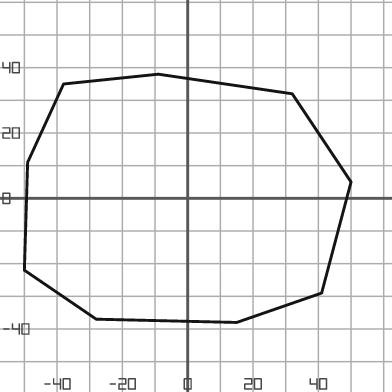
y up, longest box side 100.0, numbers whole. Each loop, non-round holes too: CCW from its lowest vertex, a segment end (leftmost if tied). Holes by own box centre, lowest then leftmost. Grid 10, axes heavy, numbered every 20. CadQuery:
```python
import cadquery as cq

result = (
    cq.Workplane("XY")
    .moveTo(15.0, -38.0)
    .lineTo(41.0, -29.0)
    .lineTo(50.0, 5.0)
    .lineTo(32.0, 32.0)
    .lineTo(-9.0, 38.0)
    .lineTo(-38.0, 35.0)
    .lineTo(-49.0, 11.0)
    .lineTo(-50.0, -22.0)
    .lineTo(-28.0, -37.0)
    .close()
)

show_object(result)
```